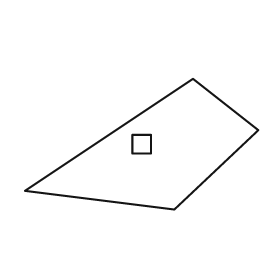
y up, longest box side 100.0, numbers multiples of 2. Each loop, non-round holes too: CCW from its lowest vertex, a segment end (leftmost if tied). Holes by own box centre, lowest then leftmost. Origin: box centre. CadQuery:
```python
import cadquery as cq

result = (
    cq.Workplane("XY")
    .moveTo(14.0, -28.0)
    .lineTo(50.0, 6.0)
    .lineTo(22.0, 28.0)
    .lineTo(-50.0, -20.0)
    .close()
    .moveTo(-4.0, -4.0)
    .lineTo(4.0, -4.0)
    .lineTo(4.0, 4.0)
    .lineTo(-4.0, 4.0)
    .close()
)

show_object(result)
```